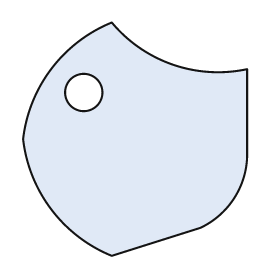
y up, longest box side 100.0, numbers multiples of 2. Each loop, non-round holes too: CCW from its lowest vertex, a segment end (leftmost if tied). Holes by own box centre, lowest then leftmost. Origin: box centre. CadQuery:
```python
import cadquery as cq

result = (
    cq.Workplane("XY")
    .moveTo(-10.0, -50.0)
    .lineTo(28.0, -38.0)
    .threePointArc((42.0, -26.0), (48.0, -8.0))
    .lineTo(48.0, 30.0)
    .threePointArc((16.0, 32.0), (-10.0, 50.0))
    .threePointArc((-36.0, 30.0), (-48.0, 0.0))
    .threePointArc((-36.0, -30.0), (-10.0, -50.0))
    .close()
    .moveTo(-22.0, 20.0)
    .circle(8.0)
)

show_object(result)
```